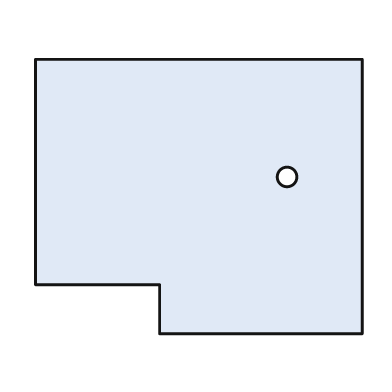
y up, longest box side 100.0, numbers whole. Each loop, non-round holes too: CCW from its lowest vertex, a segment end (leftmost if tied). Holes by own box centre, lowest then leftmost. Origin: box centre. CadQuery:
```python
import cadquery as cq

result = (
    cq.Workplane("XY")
    .moveTo(-12.0, -42.0)
    .lineTo(50.0, -42.0)
    .lineTo(50.0, 42.0)
    .lineTo(-50.0, 42.0)
    .lineTo(-50.0, -27.0)
    .lineTo(-12.0, -27.0)
    .close()
    .moveTo(27.0, 6.0)
    .circle(3.0)
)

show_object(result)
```